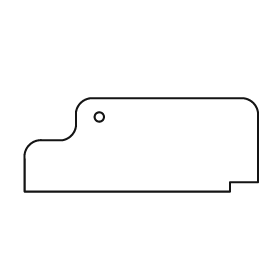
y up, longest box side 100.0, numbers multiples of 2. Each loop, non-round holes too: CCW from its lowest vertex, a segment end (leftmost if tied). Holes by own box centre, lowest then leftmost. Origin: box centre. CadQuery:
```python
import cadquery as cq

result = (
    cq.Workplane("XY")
    .moveTo(-50.0, -20.0)
    .lineTo(38.0, -20.0)
    .lineTo(38.0, -16.0)
    .lineTo(50.0, -16.0)
    .lineTo(50.0, 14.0)
    .threePointArc((48.0, 18.0), (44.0, 20.0))
    .lineTo(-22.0, 20.0)
    .threePointArc((-26.0, 18.0), (-28.0, 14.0))
    .lineTo(-28.0, 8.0)
    .threePointArc((-30.0, 4.0), (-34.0, 2.0))
    .lineTo(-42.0, 2.0)
    .threePointArc((-48.0, 0.0), (-50.0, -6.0))
    .close()
    .moveTo(-18.0, 12.0)
    .circle(2.0)
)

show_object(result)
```